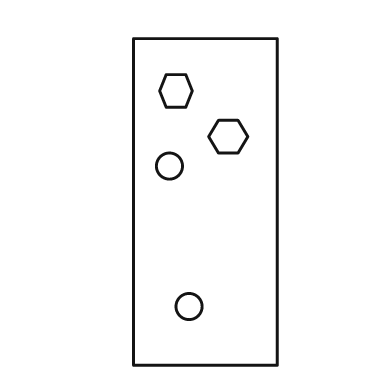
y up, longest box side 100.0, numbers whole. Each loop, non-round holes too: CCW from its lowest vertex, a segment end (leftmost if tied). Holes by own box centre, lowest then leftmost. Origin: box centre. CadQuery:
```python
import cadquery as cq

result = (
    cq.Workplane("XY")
    .moveTo(-22.0, -50.0)
    .lineTo(22.0, -50.0)
    .lineTo(22.0, 50.0)
    .lineTo(-22.0, 50.0)
    .close()
    .moveTo(-5.0, -32.0)
    .circle(4.0)
    .moveTo(-11.0, 11.0)
    .circle(4.0)
    .moveTo(4.0, 15.0)
    .lineTo(10.0, 15.0)
    .lineTo(13.0, 20.0)
    .lineTo(10.0, 25.0)
    .lineTo(4.0, 25.0)
    .lineTo(1.0, 20.0)
    .close()
    .moveTo(-12.0, 29.0)
    .lineTo(-6.0, 29.0)
    .lineTo(-4.0, 34.0)
    .lineTo(-6.0, 39.0)
    .lineTo(-12.0, 39.0)
    .lineTo(-14.0, 34.0)
    .close()
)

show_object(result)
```